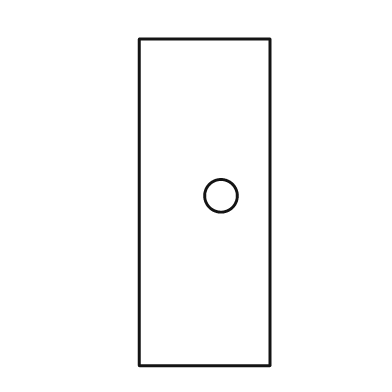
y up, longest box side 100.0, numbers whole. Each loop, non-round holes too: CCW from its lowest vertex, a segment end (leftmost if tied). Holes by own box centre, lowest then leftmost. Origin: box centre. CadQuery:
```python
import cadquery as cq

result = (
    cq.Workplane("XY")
    .moveTo(-20.0, -50.0)
    .lineTo(20.0, -50.0)
    .lineTo(20.0, 50.0)
    .lineTo(-20.0, 50.0)
    .close()
    .moveTo(5.0, 2.0)
    .circle(5.0)
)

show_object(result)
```